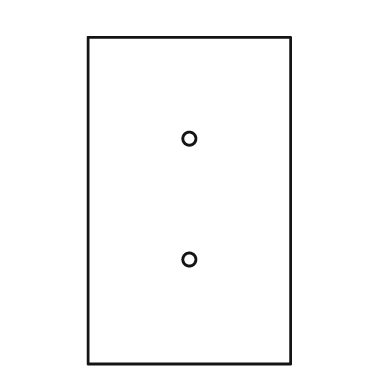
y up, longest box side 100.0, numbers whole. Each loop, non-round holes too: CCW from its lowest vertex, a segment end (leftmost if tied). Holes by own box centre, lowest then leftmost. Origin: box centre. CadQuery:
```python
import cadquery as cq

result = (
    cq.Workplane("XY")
    .moveTo(-31.0, -50.0)
    .lineTo(31.0, -50.0)
    .lineTo(31.0, 50.0)
    .lineTo(-31.0, 50.0)
    .close()
    .moveTo(0.0, -18.0)
    .circle(2.0)
    .moveTo(0.0, 19.0)
    .circle(2.0)
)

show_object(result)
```